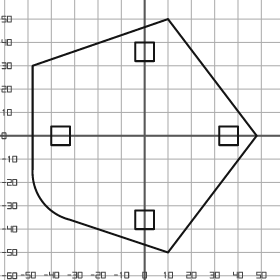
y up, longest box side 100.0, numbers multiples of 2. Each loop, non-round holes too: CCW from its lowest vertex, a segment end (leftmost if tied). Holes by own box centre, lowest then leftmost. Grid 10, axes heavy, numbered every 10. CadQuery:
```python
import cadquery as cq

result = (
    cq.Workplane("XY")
    .moveTo(10.0, -50.0)
    .lineTo(48.0, 0.0)
    .lineTo(10.0, 50.0)
    .lineTo(-48.0, 30.0)
    .lineTo(-48.0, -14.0)
    .threePointArc((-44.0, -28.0), (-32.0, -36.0))
    .close()
    .moveTo(-4.0, -40.0)
    .lineTo(4.0, -40.0)
    .lineTo(4.0, -32.0)
    .lineTo(-4.0, -32.0)
    .close()
    .moveTo(-40.0, -4.0)
    .lineTo(-32.0, -4.0)
    .lineTo(-32.0, 4.0)
    .lineTo(-40.0, 4.0)
    .close()
    .moveTo(32.0, -4.0)
    .lineTo(40.0, -4.0)
    .lineTo(40.0, 4.0)
    .lineTo(32.0, 4.0)
    .close()
    .moveTo(-4.0, 32.0)
    .lineTo(4.0, 32.0)
    .lineTo(4.0, 40.0)
    .lineTo(-4.0, 40.0)
    .close()
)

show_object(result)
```